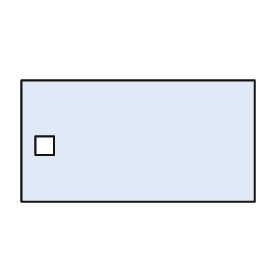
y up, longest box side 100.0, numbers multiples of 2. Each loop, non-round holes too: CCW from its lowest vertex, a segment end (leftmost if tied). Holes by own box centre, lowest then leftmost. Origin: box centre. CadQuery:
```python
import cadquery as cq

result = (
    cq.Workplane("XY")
    .moveTo(-50.0, -26.0)
    .lineTo(50.0, -26.0)
    .lineTo(50.0, 26.0)
    .lineTo(-50.0, 26.0)
    .close()
    .moveTo(-44.0, -6.0)
    .lineTo(-36.0, -6.0)
    .lineTo(-36.0, 2.0)
    .lineTo(-44.0, 2.0)
    .close()
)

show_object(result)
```